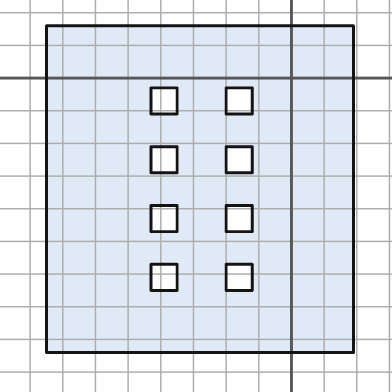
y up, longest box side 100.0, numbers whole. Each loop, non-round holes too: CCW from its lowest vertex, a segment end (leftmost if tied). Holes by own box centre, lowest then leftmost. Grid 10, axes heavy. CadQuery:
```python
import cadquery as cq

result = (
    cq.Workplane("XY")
    .moveTo(-75.0, -84.0)
    .lineTo(19.0, -84.0)
    .lineTo(19.0, 16.0)
    .lineTo(-75.0, 16.0)
    .close()
    .moveTo(-43.0, -65.0)
    .lineTo(-35.0, -65.0)
    .lineTo(-35.0, -57.0)
    .lineTo(-43.0, -57.0)
    .close()
    .moveTo(-20.0, -65.0)
    .lineTo(-12.0, -65.0)
    .lineTo(-12.0, -57.0)
    .lineTo(-20.0, -57.0)
    .close()
    .moveTo(-43.0, -47.0)
    .lineTo(-35.0, -47.0)
    .lineTo(-35.0, -39.0)
    .lineTo(-43.0, -39.0)
    .close()
    .moveTo(-20.0, -47.0)
    .lineTo(-12.0, -47.0)
    .lineTo(-12.0, -39.0)
    .lineTo(-20.0, -39.0)
    .close()
    .moveTo(-43.0, -29.0)
    .lineTo(-35.0, -29.0)
    .lineTo(-35.0, -21.0)
    .lineTo(-43.0, -21.0)
    .close()
    .moveTo(-20.0, -29.0)
    .lineTo(-12.0, -29.0)
    .lineTo(-12.0, -21.0)
    .lineTo(-20.0, -21.0)
    .close()
    .moveTo(-43.0, -11.0)
    .lineTo(-35.0, -11.0)
    .lineTo(-35.0, -3.0)
    .lineTo(-43.0, -3.0)
    .close()
    .moveTo(-20.0, -11.0)
    .lineTo(-12.0, -11.0)
    .lineTo(-12.0, -3.0)
    .lineTo(-20.0, -3.0)
    .close()
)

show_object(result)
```